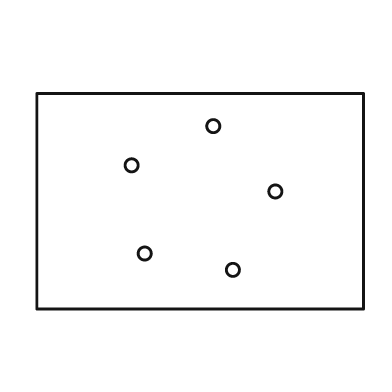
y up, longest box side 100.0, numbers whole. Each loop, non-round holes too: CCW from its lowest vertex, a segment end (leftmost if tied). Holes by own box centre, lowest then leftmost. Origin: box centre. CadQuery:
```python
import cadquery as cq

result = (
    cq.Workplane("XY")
    .moveTo(-50.0, -33.0)
    .lineTo(50.0, -33.0)
    .lineTo(50.0, 33.0)
    .lineTo(-50.0, 33.0)
    .close()
    .moveTo(10.0, -21.0)
    .circle(2.0)
    .moveTo(-17.0, -16.0)
    .circle(2.0)
    .moveTo(23.0, 3.0)
    .circle(2.0)
    .moveTo(-21.0, 11.0)
    .circle(2.0)
    .moveTo(4.0, 23.0)
    .circle(2.0)
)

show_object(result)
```